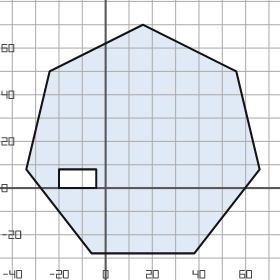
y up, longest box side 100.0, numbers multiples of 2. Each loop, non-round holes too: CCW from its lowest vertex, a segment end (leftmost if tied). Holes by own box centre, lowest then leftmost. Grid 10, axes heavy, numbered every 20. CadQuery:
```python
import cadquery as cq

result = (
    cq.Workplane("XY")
    .moveTo(-6.0, -28.0)
    .lineTo(38.0, -28.0)
    .lineTo(66.0, 8.0)
    .lineTo(56.0, 50.0)
    .lineTo(16.0, 70.0)
    .lineTo(-24.0, 50.0)
    .lineTo(-34.0, 8.0)
    .close()
    .moveTo(-20.0, 0.0)
    .lineTo(-4.0, 0.0)
    .lineTo(-4.0, 8.0)
    .lineTo(-20.0, 8.0)
    .close()
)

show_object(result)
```